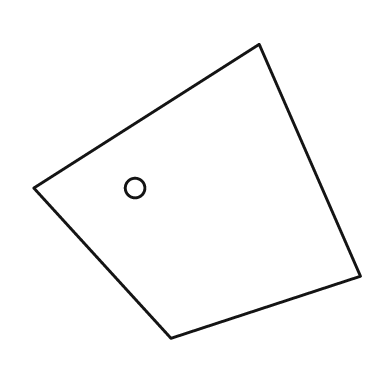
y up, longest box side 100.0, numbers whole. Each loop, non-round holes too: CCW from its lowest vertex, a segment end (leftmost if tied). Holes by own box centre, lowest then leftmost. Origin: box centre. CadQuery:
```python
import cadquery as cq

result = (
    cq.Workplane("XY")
    .moveTo(-8.0, -45.0)
    .lineTo(50.0, -26.0)
    .lineTo(19.0, 45.0)
    .lineTo(-50.0, 1.0)
    .close()
    .moveTo(-19.0, 1.0)
    .circle(3.0)
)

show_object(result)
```